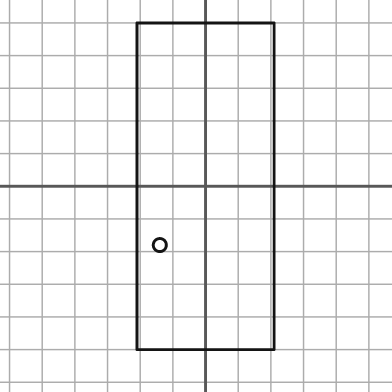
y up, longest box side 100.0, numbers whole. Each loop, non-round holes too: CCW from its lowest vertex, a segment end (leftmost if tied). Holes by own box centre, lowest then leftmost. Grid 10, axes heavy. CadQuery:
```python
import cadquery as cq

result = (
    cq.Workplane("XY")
    .moveTo(-21.0, -50.0)
    .lineTo(21.0, -50.0)
    .lineTo(21.0, 50.0)
    .lineTo(-21.0, 50.0)
    .close()
    .moveTo(-14.0, -18.0)
    .circle(2.0)
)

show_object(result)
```